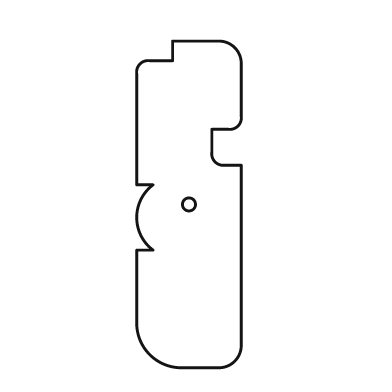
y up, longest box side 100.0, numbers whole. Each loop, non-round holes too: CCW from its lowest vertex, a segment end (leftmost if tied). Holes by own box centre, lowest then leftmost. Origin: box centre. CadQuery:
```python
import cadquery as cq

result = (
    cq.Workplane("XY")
    .moveTo(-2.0, -50.0)
    .lineTo(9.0, -50.0)
    .threePointArc((14.0, -48.0), (16.0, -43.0))
    .lineTo(16.0, 12.0)
    .lineTo(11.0, 12.0)
    .threePointArc((8.0, 13.0), (7.0, 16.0))
    .lineTo(7.0, 23.0)
    .lineTo(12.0, 23.0)
    .threePointArc((15.0, 24.0), (16.0, 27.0))
    .lineTo(16.0, 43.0)
    .threePointArc((14.0, 48.0), (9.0, 50.0))
    .lineTo(-5.0, 50.0)
    .lineTo(-5.0, 44.0)
    .lineTo(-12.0, 44.0)
    .threePointArc((-15.0, 43.0), (-16.0, 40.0))
    .lineTo(-16.0, 6.0)
    .lineTo(-11.0, 6.0)
    .threePointArc((-16.0, -4.0), (-11.0, -14.0))
    .lineTo(-16.0, -14.0)
    .lineTo(-16.0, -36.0)
    .threePointArc((-12.0, -46.0), (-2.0, -50.0))
    .close()
    .moveTo(0.0, 0.0)
    .circle(2.0)
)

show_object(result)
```